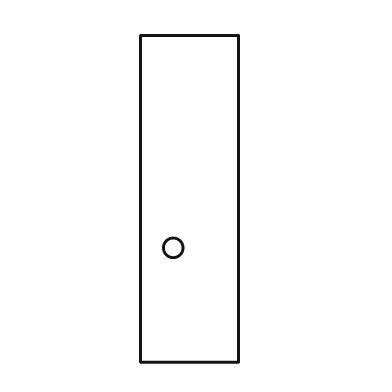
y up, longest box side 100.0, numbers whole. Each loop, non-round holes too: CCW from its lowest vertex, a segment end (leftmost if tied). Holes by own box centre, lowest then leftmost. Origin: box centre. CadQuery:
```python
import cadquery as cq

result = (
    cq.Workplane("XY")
    .moveTo(-15.0, -50.0)
    .lineTo(15.0, -50.0)
    .lineTo(15.0, 50.0)
    .lineTo(-15.0, 50.0)
    .close()
    .moveTo(-5.0, -15.0)
    .circle(3.0)
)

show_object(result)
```